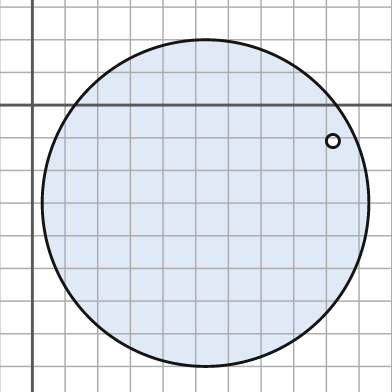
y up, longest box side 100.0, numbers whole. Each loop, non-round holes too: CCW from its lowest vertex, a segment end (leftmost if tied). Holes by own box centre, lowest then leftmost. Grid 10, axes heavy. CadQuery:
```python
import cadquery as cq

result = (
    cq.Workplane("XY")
    .moveTo(53.0, -30.0)
    .circle(50.0)
    .moveTo(92.0, -11.0)
    .circle(2.0)
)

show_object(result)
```